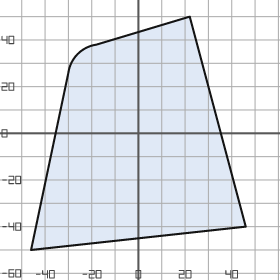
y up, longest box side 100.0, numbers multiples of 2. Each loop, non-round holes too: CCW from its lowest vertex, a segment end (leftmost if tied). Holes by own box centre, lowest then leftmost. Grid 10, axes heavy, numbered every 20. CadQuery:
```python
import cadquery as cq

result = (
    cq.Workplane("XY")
    .moveTo(-46.0, -50.0)
    .lineTo(46.0, -40.0)
    .lineTo(22.0, 50.0)
    .lineTo(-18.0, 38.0)
    .threePointArc((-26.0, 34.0), (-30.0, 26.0))
    .close()
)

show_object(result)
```